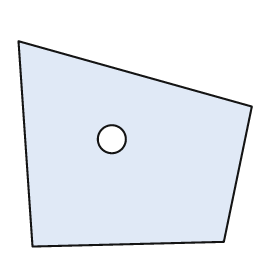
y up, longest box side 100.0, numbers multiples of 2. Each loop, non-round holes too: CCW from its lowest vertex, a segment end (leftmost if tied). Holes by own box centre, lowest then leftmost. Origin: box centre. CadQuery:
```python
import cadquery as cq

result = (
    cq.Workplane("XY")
    .moveTo(-44.0, -44.0)
    .lineTo(38.0, -42.0)
    .lineTo(50.0, 16.0)
    .lineTo(-50.0, 44.0)
    .close()
    .moveTo(-10.0, 2.0)
    .circle(6.0)
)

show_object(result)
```